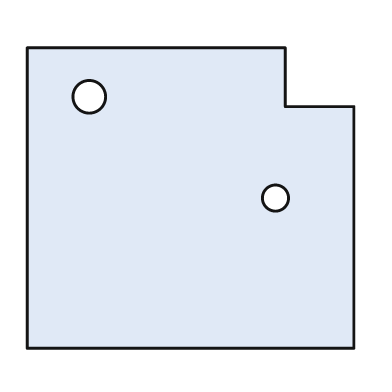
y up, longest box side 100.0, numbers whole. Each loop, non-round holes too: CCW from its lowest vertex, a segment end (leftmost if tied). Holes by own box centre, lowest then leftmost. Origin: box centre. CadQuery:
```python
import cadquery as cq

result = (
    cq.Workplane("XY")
    .moveTo(-50.0, -46.0)
    .lineTo(50.0, -46.0)
    .lineTo(50.0, 28.0)
    .lineTo(29.0, 28.0)
    .lineTo(29.0, 46.0)
    .lineTo(-50.0, 46.0)
    .close()
    .moveTo(26.0, 0.0)
    .circle(4.0)
    .moveTo(-31.0, 31.0)
    .circle(5.0)
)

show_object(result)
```